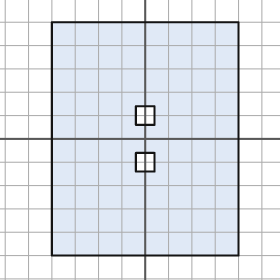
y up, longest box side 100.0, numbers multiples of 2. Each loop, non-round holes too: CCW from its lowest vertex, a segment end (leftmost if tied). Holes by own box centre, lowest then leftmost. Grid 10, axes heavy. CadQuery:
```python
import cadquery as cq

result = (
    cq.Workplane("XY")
    .moveTo(-40.0, -50.0)
    .lineTo(40.0, -50.0)
    .lineTo(40.0, 50.0)
    .lineTo(-40.0, 50.0)
    .close()
    .moveTo(-4.0, -14.0)
    .lineTo(4.0, -14.0)
    .lineTo(4.0, -6.0)
    .lineTo(-4.0, -6.0)
    .close()
    .moveTo(-4.0, 6.0)
    .lineTo(4.0, 6.0)
    .lineTo(4.0, 14.0)
    .lineTo(-4.0, 14.0)
    .close()
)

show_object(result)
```